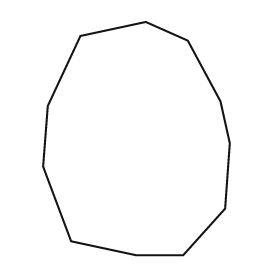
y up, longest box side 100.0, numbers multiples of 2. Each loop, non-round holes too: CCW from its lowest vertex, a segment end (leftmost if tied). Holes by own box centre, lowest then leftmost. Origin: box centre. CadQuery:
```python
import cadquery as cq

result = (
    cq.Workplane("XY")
    .moveTo(0.0, -50.0)
    .lineTo(20.0, -50.0)
    .lineTo(38.0, -30.0)
    .lineTo(40.0, -2.0)
    .lineTo(36.0, 16.0)
    .lineTo(22.0, 42.0)
    .lineTo(4.0, 50.0)
    .lineTo(-24.0, 44.0)
    .lineTo(-38.0, 14.0)
    .lineTo(-40.0, -12.0)
    .lineTo(-28.0, -44.0)
    .close()
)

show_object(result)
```